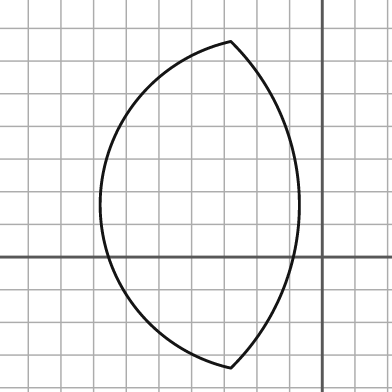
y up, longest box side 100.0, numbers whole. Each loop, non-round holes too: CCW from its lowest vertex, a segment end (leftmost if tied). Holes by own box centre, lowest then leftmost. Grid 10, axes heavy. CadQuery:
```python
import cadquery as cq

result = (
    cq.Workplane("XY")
    .moveTo(-28.0, -34.0)
    .threePointArc((-7.0, 16.0), (-28.0, 66.0))
    .threePointArc((-68.0, 16.0), (-28.0, -34.0))
    .close()
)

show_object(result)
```